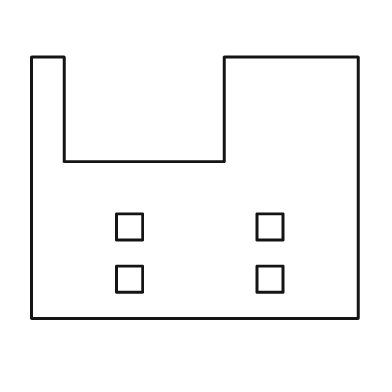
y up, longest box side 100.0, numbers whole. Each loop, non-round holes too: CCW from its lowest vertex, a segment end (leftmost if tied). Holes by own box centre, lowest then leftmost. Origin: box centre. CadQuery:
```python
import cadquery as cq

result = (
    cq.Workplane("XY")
    .moveTo(-50.0, -40.0)
    .lineTo(50.0, -40.0)
    .lineTo(50.0, 40.0)
    .lineTo(9.0, 40.0)
    .lineTo(9.0, 8.0)
    .lineTo(-40.0, 8.0)
    .lineTo(-40.0, 40.0)
    .lineTo(-50.0, 40.0)
    .close()
    .moveTo(-24.0, -32.0)
    .lineTo(-16.0, -32.0)
    .lineTo(-16.0, -24.0)
    .lineTo(-24.0, -24.0)
    .close()
    .moveTo(19.0, -32.0)
    .lineTo(27.0, -32.0)
    .lineTo(27.0, -24.0)
    .lineTo(19.0, -24.0)
    .close()
    .moveTo(-24.0, -16.0)
    .lineTo(-16.0, -16.0)
    .lineTo(-16.0, -8.0)
    .lineTo(-24.0, -8.0)
    .close()
    .moveTo(19.0, -16.0)
    .lineTo(27.0, -16.0)
    .lineTo(27.0, -8.0)
    .lineTo(19.0, -8.0)
    .close()
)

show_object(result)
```